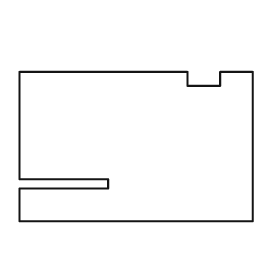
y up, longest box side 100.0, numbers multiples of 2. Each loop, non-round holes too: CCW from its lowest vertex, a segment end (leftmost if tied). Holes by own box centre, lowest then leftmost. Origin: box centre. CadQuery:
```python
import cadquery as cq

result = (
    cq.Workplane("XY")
    .moveTo(-50.0, -32.0)
    .lineTo(50.0, -32.0)
    .lineTo(50.0, 32.0)
    .lineTo(36.0, 32.0)
    .lineTo(36.0, 26.0)
    .lineTo(22.0, 26.0)
    .lineTo(22.0, 32.0)
    .lineTo(-50.0, 32.0)
    .lineTo(-50.0, -14.0)
    .lineTo(-12.0, -14.0)
    .lineTo(-12.0, -18.0)
    .lineTo(-50.0, -18.0)
    .close()
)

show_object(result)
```